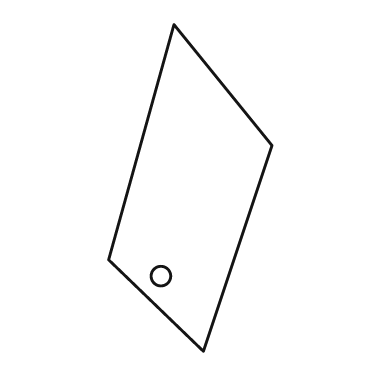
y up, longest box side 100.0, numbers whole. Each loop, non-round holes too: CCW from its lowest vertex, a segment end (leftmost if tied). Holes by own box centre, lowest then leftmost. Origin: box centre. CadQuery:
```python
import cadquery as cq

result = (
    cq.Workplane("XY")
    .moveTo(4.0, -50.0)
    .lineTo(25.0, 13.0)
    .lineTo(-5.0, 50.0)
    .lineTo(-25.0, -22.0)
    .close()
    .moveTo(-9.0, -27.0)
    .circle(3.0)
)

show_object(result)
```